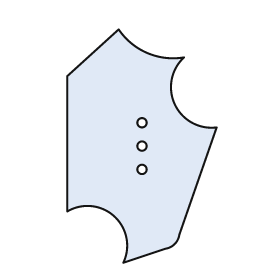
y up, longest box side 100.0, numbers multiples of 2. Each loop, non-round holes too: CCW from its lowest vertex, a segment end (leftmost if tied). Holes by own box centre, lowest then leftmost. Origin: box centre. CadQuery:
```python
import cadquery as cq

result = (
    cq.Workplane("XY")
    .moveTo(-8.0, -50.0)
    .lineTo(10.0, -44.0)
    .threePointArc((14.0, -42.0), (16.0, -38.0))
    .lineTo(32.0, 8.0)
    .threePointArc((14.0, 18.0), (18.0, 38.0))
    .threePointArc((2.0, 40.0), (-10.0, 50.0))
    .lineTo(-32.0, 30.0)
    .lineTo(-32.0, -28.0)
    .threePointArc((-12.0, -30.0), (-8.0, -50.0))
    .close()
    .moveTo(0.0, -10.0)
    .circle(2.0)
    .moveTo(0.0, 0.0)
    .circle(2.0)
    .moveTo(0.0, 10.0)
    .circle(2.0)
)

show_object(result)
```